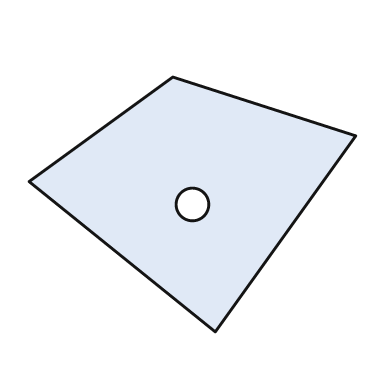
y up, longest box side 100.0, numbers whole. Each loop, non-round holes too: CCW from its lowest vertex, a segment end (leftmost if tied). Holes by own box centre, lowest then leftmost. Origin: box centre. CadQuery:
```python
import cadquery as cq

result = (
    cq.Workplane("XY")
    .moveTo(7.0, -39.0)
    .lineTo(50.0, 21.0)
    .lineTo(-6.0, 39.0)
    .lineTo(-50.0, 7.0)
    .close()
    .moveTo(0.0, 0.0)
    .circle(5.0)
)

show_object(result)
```